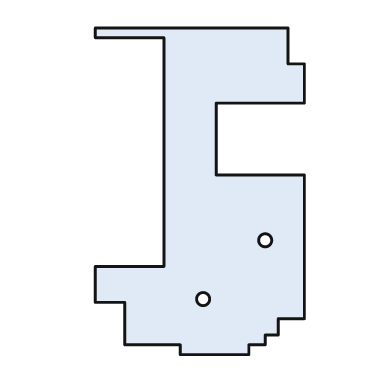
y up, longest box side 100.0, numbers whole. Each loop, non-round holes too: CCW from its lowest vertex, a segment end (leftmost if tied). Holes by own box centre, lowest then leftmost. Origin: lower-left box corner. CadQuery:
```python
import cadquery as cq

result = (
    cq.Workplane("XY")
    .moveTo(26.0, 0.0)
    .lineTo(47.0, 0.0)
    .lineTo(47.0, 3.0)
    .lineTo(52.0, 3.0)
    .lineTo(52.0, 6.0)
    .lineTo(56.0, 6.0)
    .lineTo(56.0, 11.0)
    .lineTo(64.0, 11.0)
    .lineTo(64.0, 55.0)
    .lineTo(37.0, 55.0)
    .lineTo(37.0, 77.0)
    .lineTo(64.0, 77.0)
    .lineTo(64.0, 89.0)
    .lineTo(59.0, 89.0)
    .lineTo(59.0, 100.0)
    .lineTo(0.0, 100.0)
    .lineTo(0.0, 97.0)
    .lineTo(21.0, 97.0)
    .lineTo(21.0, 27.0)
    .lineTo(0.0, 27.0)
    .lineTo(0.0, 16.0)
    .lineTo(9.0, 16.0)
    .lineTo(9.0, 3.0)
    .lineTo(26.0, 3.0)
    .close()
    .moveTo(33.0, 17.0)
    .circle(2.0)
    .moveTo(52.0, 35.0)
    .circle(2.0)
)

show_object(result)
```